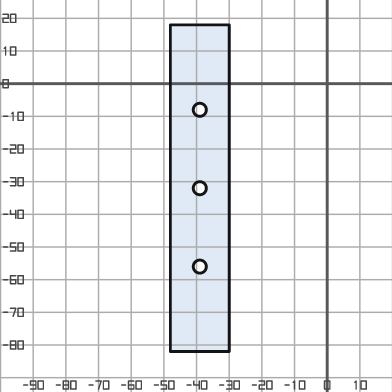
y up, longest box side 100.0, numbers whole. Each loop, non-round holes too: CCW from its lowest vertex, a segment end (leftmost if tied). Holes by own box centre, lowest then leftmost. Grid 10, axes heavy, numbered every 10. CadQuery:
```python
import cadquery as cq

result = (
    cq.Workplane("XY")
    .moveTo(-48.0, -82.0)
    .lineTo(-30.0, -82.0)
    .lineTo(-30.0, 18.0)
    .lineTo(-48.0, 18.0)
    .close()
    .moveTo(-39.0, -56.0)
    .circle(2.0)
    .moveTo(-39.0, -32.0)
    .circle(2.0)
    .moveTo(-39.0, -8.0)
    .circle(2.0)
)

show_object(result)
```